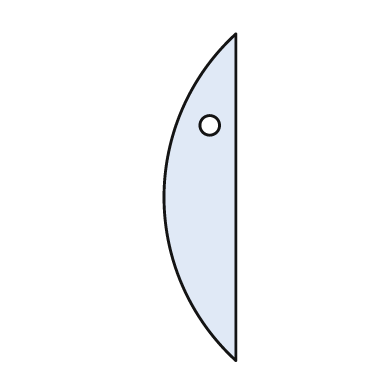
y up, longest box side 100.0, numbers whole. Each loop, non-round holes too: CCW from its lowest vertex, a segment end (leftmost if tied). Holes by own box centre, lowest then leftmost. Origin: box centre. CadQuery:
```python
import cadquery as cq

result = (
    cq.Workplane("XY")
    .moveTo(11.0, -50.0)
    .lineTo(11.0, 50.0)
    .threePointArc((-11.0, 0.0), (11.0, -50.0))
    .close()
    .moveTo(3.0, 22.0)
    .circle(3.0)
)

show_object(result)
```